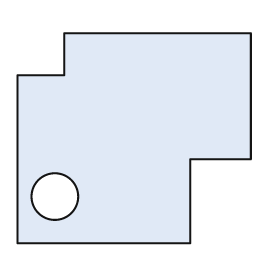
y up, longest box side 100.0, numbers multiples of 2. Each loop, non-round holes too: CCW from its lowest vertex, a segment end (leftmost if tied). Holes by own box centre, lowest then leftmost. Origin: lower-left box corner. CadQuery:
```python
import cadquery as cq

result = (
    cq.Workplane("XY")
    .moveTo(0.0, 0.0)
    .lineTo(74.0, 0.0)
    .lineTo(74.0, 36.0)
    .lineTo(100.0, 36.0)
    .lineTo(100.0, 90.0)
    .lineTo(20.0, 90.0)
    .lineTo(20.0, 72.0)
    .lineTo(0.0, 72.0)
    .close()
    .moveTo(16.0, 20.0)
    .circle(10.0)
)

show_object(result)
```